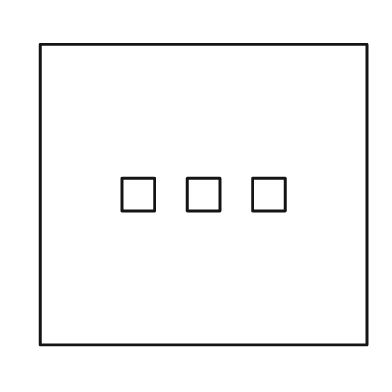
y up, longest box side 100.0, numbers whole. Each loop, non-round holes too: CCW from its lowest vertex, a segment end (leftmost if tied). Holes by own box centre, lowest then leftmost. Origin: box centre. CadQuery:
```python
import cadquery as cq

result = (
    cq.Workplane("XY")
    .moveTo(-50.0, -46.0)
    .lineTo(50.0, -46.0)
    .lineTo(50.0, 46.0)
    .lineTo(-50.0, 46.0)
    .close()
    .moveTo(-25.0, -5.0)
    .lineTo(-15.0, -5.0)
    .lineTo(-15.0, 5.0)
    .lineTo(-25.0, 5.0)
    .close()
    .moveTo(-5.0, -5.0)
    .lineTo(5.0, -5.0)
    .lineTo(5.0, 5.0)
    .lineTo(-5.0, 5.0)
    .close()
    .moveTo(15.0, -5.0)
    .lineTo(25.0, -5.0)
    .lineTo(25.0, 5.0)
    .lineTo(15.0, 5.0)
    .close()
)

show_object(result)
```